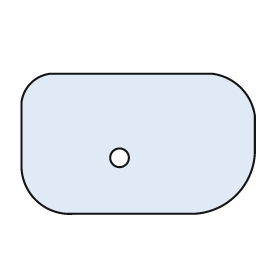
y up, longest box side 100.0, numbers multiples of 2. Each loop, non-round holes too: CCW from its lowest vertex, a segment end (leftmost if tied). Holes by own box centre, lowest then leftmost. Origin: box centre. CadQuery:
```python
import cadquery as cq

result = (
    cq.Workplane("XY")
    .moveTo(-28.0, -30.0)
    .lineTo(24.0, -30.0)
    .threePointArc((42.0, -22.0), (50.0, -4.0))
    .lineTo(50.0, 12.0)
    .threePointArc((44.0, 24.0), (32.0, 30.0))
    .lineTo(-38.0, 30.0)
    .threePointArc((-46.0, 26.0), (-50.0, 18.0))
    .lineTo(-50.0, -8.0)
    .threePointArc((-44.0, -24.0), (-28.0, -30.0))
    .close()
    .moveTo(-8.0, -6.0)
    .circle(4.0)
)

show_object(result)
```